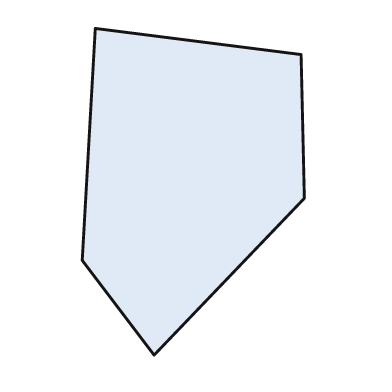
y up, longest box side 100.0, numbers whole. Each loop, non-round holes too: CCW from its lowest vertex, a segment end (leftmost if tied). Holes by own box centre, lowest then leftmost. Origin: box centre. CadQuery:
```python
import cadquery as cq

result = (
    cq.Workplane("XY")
    .moveTo(-12.0, -50.0)
    .lineTo(34.0, -2.0)
    .lineTo(33.0, 42.0)
    .lineTo(-30.0, 50.0)
    .lineTo(-34.0, -21.0)
    .close()
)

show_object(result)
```